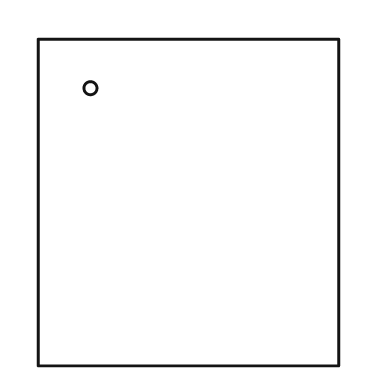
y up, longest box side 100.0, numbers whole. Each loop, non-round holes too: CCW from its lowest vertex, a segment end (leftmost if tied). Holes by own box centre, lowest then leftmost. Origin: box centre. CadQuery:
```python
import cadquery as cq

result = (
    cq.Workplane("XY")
    .moveTo(-46.0, -50.0)
    .lineTo(46.0, -50.0)
    .lineTo(46.0, 50.0)
    .lineTo(-46.0, 50.0)
    .close()
    .moveTo(-30.0, 35.0)
    .circle(2.0)
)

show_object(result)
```